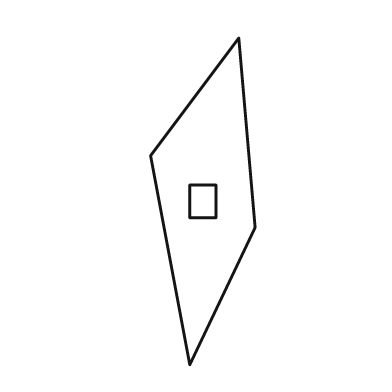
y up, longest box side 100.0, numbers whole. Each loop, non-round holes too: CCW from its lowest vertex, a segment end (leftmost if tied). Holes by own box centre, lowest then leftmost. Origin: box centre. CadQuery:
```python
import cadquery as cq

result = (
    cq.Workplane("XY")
    .moveTo(-4.0, -50.0)
    .lineTo(16.0, -8.0)
    .lineTo(11.0, 50.0)
    .lineTo(-16.0, 14.0)
    .close()
    .moveTo(-4.0, -5.0)
    .lineTo(4.0, -5.0)
    .lineTo(4.0, 5.0)
    .lineTo(-4.0, 5.0)
    .close()
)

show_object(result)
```